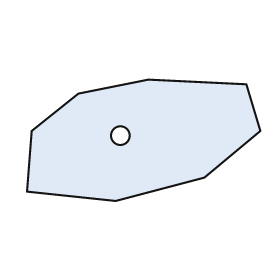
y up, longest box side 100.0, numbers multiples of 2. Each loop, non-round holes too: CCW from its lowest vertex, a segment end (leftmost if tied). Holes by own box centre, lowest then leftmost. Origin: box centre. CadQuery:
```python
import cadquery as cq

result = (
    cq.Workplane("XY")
    .moveTo(-12.0, -26.0)
    .lineTo(26.0, -16.0)
    .lineTo(50.0, 4.0)
    .lineTo(44.0, 24.0)
    .lineTo(2.0, 26.0)
    .lineTo(-28.0, 20.0)
    .lineTo(-48.0, 4.0)
    .lineTo(-50.0, -22.0)
    .close()
    .moveTo(-10.0, 2.0)
    .circle(4.0)
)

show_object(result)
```